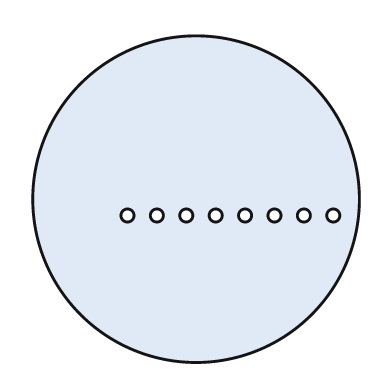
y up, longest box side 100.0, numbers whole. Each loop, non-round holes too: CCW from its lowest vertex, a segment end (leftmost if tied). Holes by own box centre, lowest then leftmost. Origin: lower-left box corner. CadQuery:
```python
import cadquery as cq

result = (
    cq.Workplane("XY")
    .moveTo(50.0, 50.0)
    .circle(50.0)
    .moveTo(29.0, 45.0)
    .circle(2.0)
    .moveTo(38.0, 45.0)
    .circle(2.0)
    .moveTo(47.0, 45.0)
    .circle(2.0)
    .moveTo(56.0, 45.0)
    .circle(2.0)
    .moveTo(65.0, 45.0)
    .circle(2.0)
    .moveTo(74.0, 45.0)
    .circle(2.0)
    .moveTo(83.0, 45.0)
    .circle(2.0)
    .moveTo(92.0, 45.0)
    .circle(2.0)
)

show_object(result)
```